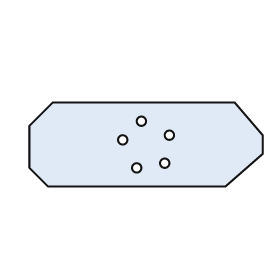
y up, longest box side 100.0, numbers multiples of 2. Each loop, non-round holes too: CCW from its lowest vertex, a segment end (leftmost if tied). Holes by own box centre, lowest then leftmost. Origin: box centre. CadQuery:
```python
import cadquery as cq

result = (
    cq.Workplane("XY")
    .moveTo(-42.0, -18.0)
    .lineTo(34.0, -18.0)
    .lineTo(50.0, -4.0)
    .lineTo(50.0, 4.0)
    .lineTo(38.0, 18.0)
    .lineTo(-40.0, 18.0)
    .lineTo(-50.0, 8.0)
    .lineTo(-50.0, -10.0)
    .close()
    .moveTo(-4.0, -10.0)
    .circle(2.0)
    .moveTo(8.0, -8.0)
    .circle(2.0)
    .moveTo(-10.0, 2.0)
    .circle(2.0)
    .moveTo(10.0, 4.0)
    .circle(2.0)
    .moveTo(-2.0, 10.0)
    .circle(2.0)
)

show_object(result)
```